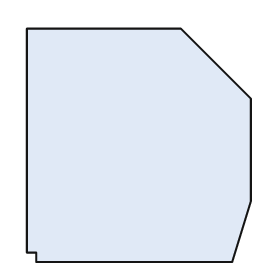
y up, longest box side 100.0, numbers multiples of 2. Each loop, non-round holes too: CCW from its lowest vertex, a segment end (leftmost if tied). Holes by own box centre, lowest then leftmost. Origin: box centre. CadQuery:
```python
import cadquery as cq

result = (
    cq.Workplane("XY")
    .moveTo(-44.0, -50.0)
    .lineTo(40.0, -50.0)
    .lineTo(48.0, -24.0)
    .lineTo(48.0, 20.0)
    .lineTo(18.0, 50.0)
    .lineTo(-48.0, 50.0)
    .lineTo(-48.0, -46.0)
    .lineTo(-44.0, -46.0)
    .close()
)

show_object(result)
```